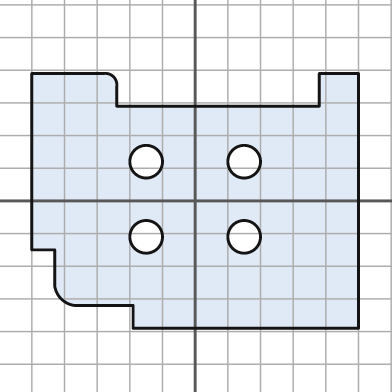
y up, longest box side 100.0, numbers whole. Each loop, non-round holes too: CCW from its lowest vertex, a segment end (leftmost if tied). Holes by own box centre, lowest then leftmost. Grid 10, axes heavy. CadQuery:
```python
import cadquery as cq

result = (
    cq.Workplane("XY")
    .moveTo(-19.0, -39.0)
    .lineTo(50.0, -39.0)
    .lineTo(50.0, 39.0)
    .lineTo(38.0, 39.0)
    .lineTo(38.0, 29.0)
    .lineTo(-24.0, 29.0)
    .lineTo(-24.0, 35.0)
    .threePointArc((-25.0, 38.0), (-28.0, 39.0))
    .lineTo(-50.0, 39.0)
    .lineTo(-50.0, -15.0)
    .lineTo(-43.0, -15.0)
    .lineTo(-43.0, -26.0)
    .threePointArc((-41.0, -30.0), (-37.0, -32.0))
    .lineTo(-19.0, -32.0)
    .close()
    .moveTo(-15.0, -11.0)
    .circle(5.0)
    .moveTo(15.0, -11.0)
    .circle(5.0)
    .moveTo(-15.0, 12.0)
    .circle(5.0)
    .moveTo(15.0, 12.0)
    .circle(5.0)
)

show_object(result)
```